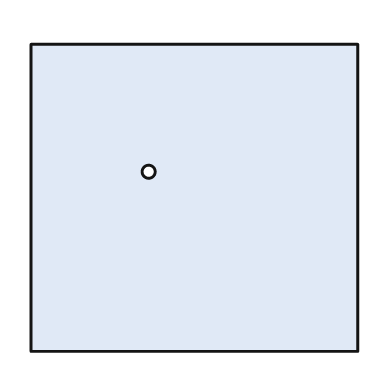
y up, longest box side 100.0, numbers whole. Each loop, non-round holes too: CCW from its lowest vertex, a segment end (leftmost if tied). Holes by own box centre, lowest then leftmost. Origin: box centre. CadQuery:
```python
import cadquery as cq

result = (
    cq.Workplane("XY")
    .moveTo(-50.0, -47.0)
    .lineTo(50.0, -47.0)
    .lineTo(50.0, 47.0)
    .lineTo(-50.0, 47.0)
    .close()
    .moveTo(-14.0, 8.0)
    .circle(2.0)
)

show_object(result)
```